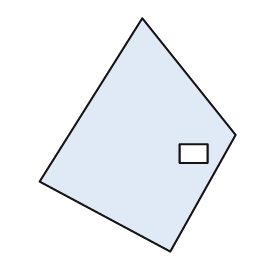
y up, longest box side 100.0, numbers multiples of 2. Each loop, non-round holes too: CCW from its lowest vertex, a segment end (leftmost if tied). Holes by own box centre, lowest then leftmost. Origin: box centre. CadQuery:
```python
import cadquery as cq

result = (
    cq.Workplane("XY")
    .moveTo(14.0, -50.0)
    .lineTo(42.0, 0.0)
    .lineTo(2.0, 50.0)
    .lineTo(-42.0, -20.0)
    .close()
    .moveTo(18.0, -12.0)
    .lineTo(30.0, -12.0)
    .lineTo(30.0, -4.0)
    .lineTo(18.0, -4.0)
    .close()
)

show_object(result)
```